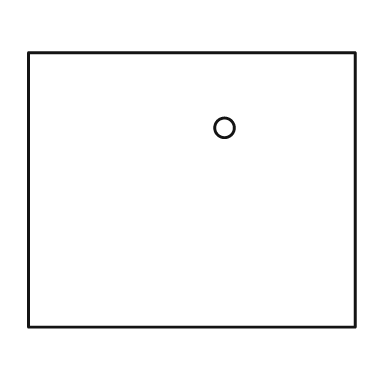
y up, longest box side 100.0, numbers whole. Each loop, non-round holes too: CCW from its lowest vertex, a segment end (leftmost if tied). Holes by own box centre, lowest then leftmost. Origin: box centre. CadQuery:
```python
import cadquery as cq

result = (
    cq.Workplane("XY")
    .moveTo(-50.0, -42.0)
    .lineTo(50.0, -42.0)
    .lineTo(50.0, 42.0)
    .lineTo(-50.0, 42.0)
    .close()
    .moveTo(10.0, 19.0)
    .circle(3.0)
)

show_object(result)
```